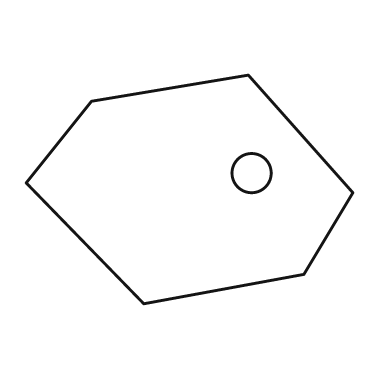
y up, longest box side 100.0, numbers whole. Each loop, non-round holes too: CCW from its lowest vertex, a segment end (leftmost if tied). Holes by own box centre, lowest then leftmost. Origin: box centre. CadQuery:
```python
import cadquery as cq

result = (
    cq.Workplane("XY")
    .moveTo(-14.0, -35.0)
    .lineTo(35.0, -26.0)
    .lineTo(50.0, -1.0)
    .lineTo(18.0, 35.0)
    .lineTo(-30.0, 27.0)
    .lineTo(-50.0, 2.0)
    .close()
    .moveTo(19.0, 5.0)
    .circle(6.0)
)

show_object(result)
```